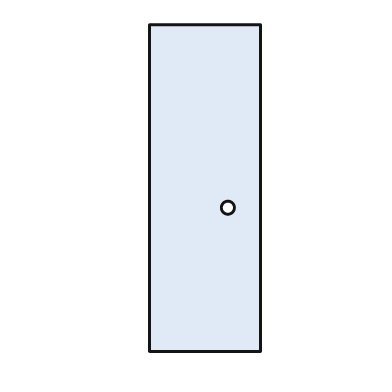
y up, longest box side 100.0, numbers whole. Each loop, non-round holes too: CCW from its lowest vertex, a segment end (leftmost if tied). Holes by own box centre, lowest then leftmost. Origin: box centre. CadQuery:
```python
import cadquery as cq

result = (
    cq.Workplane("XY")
    .moveTo(-17.0, -50.0)
    .lineTo(17.0, -50.0)
    .lineTo(17.0, 50.0)
    .lineTo(-17.0, 50.0)
    .close()
    .moveTo(7.0, -6.0)
    .circle(2.0)
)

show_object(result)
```